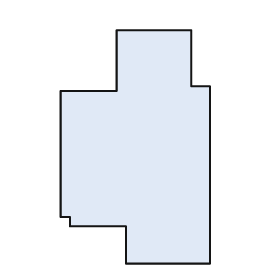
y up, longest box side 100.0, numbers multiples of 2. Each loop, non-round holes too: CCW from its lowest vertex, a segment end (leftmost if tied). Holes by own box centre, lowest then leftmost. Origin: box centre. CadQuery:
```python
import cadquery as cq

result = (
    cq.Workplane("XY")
    .moveTo(-4.0, -50.0)
    .lineTo(32.0, -50.0)
    .lineTo(32.0, 26.0)
    .lineTo(24.0, 26.0)
    .lineTo(24.0, 50.0)
    .lineTo(-8.0, 50.0)
    .lineTo(-8.0, 24.0)
    .lineTo(-32.0, 24.0)
    .lineTo(-32.0, -30.0)
    .lineTo(-28.0, -30.0)
    .lineTo(-28.0, -34.0)
    .lineTo(-4.0, -34.0)
    .close()
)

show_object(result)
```